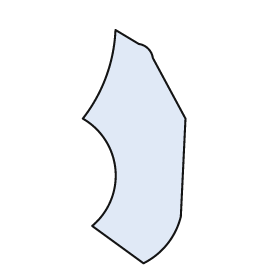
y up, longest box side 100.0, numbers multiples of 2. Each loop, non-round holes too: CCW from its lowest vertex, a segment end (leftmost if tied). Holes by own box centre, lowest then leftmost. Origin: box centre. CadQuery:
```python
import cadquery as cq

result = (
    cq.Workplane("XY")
    .moveTo(4.0, -50.0)
    .threePointArc((14.0, -42.0), (20.0, -30.0))
    .lineTo(22.0, 12.0)
    .lineTo(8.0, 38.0)
    .threePointArc((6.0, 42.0), (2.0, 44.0))
    .lineTo(-8.0, 50.0)
    .threePointArc((-12.0, 30.0), (-22.0, 12.0))
    .threePointArc((-8.0, -10.0), (-18.0, -34.0))
    .close()
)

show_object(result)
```